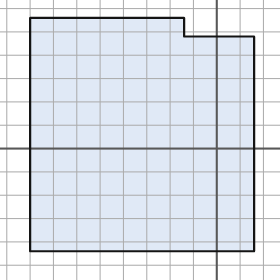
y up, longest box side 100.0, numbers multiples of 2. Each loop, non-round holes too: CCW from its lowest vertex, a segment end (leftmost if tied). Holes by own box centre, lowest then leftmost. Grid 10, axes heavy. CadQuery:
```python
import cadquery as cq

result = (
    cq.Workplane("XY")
    .moveTo(-80.0, -44.0)
    .lineTo(16.0, -44.0)
    .lineTo(16.0, 48.0)
    .lineTo(-14.0, 48.0)
    .lineTo(-14.0, 56.0)
    .lineTo(-80.0, 56.0)
    .close()
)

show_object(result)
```